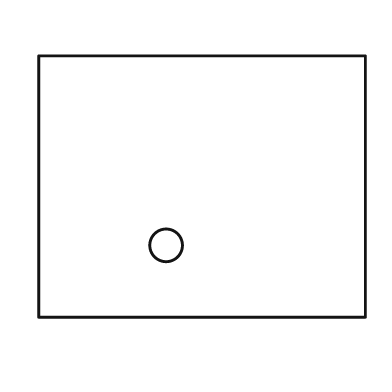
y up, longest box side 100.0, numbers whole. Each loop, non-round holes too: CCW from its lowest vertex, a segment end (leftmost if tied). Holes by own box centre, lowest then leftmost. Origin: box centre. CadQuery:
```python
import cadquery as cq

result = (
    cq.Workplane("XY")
    .moveTo(-50.0, -40.0)
    .lineTo(50.0, -40.0)
    .lineTo(50.0, 40.0)
    .lineTo(-50.0, 40.0)
    .close()
    .moveTo(-11.0, -18.0)
    .circle(5.0)
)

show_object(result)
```